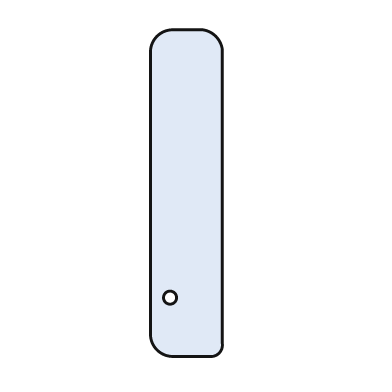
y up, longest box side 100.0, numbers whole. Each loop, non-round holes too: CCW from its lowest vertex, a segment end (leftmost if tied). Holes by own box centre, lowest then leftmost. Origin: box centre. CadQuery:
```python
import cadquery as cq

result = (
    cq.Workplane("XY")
    .moveTo(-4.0, -50.0)
    .lineTo(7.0, -50.0)
    .threePointArc((10.0, -49.0), (11.0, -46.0))
    .lineTo(11.0, 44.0)
    .threePointArc((9.0, 48.0), (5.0, 50.0))
    .lineTo(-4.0, 50.0)
    .threePointArc((-9.0, 48.0), (-11.0, 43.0))
    .lineTo(-11.0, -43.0)
    .threePointArc((-9.0, -48.0), (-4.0, -50.0))
    .close()
    .moveTo(-5.0, -32.0)
    .circle(2.0)
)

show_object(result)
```